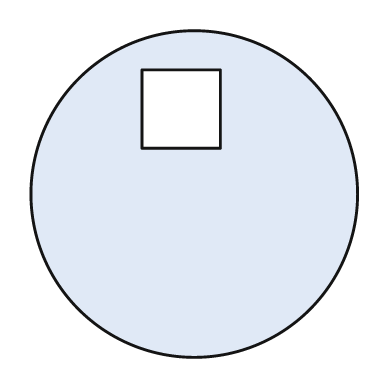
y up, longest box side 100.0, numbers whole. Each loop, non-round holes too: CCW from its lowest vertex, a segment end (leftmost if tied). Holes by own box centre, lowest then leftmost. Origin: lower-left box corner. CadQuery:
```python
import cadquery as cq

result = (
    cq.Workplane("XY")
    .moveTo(50.0, 50.0)
    .circle(50.0)
    .moveTo(34.0, 64.0)
    .lineTo(58.0, 64.0)
    .lineTo(58.0, 88.0)
    .lineTo(34.0, 88.0)
    .close()
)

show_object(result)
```